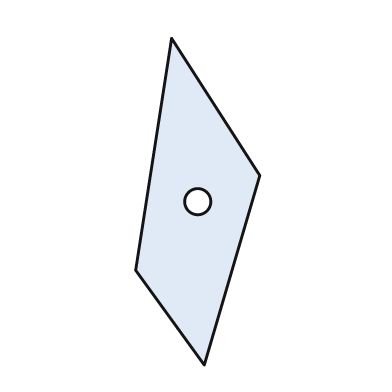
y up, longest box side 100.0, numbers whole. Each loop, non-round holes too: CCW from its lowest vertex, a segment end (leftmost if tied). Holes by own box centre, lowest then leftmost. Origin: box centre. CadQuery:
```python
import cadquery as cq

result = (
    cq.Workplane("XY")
    .moveTo(2.0, -50.0)
    .lineTo(19.0, 8.0)
    .lineTo(-8.0, 50.0)
    .lineTo(-19.0, -21.0)
    .close()
    .moveTo(0.0, 0.0)
    .circle(4.0)
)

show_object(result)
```